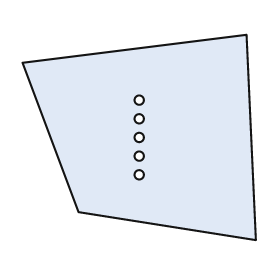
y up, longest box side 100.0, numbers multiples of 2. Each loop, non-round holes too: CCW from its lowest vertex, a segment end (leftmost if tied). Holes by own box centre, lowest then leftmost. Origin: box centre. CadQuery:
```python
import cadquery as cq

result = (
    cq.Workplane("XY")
    .moveTo(50.0, -44.0)
    .lineTo(46.0, 44.0)
    .lineTo(-50.0, 32.0)
    .lineTo(-26.0, -32.0)
    .close()
    .moveTo(0.0, -16.0)
    .circle(2.0)
    .moveTo(0.0, -8.0)
    .circle(2.0)
    .moveTo(0.0, 0.0)
    .circle(2.0)
    .moveTo(0.0, 8.0)
    .circle(2.0)
    .moveTo(0.0, 16.0)
    .circle(2.0)
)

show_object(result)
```